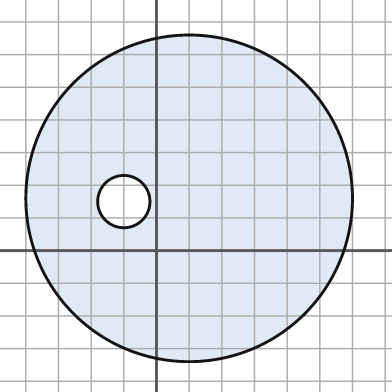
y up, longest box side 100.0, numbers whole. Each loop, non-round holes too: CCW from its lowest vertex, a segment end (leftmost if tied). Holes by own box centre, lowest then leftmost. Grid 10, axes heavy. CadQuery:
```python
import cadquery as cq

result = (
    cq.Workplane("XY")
    .moveTo(10.0, 16.0)
    .circle(50.0)
    .moveTo(-10.0, 15.0)
    .circle(8.0)
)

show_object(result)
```